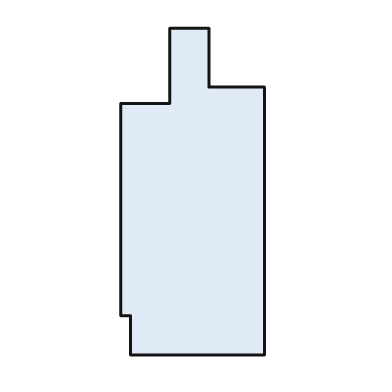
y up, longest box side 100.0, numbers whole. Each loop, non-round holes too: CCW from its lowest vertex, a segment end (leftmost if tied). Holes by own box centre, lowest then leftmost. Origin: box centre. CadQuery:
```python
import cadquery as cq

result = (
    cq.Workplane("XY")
    .moveTo(-19.0, -50.0)
    .lineTo(22.0, -50.0)
    .lineTo(22.0, 32.0)
    .lineTo(5.0, 32.0)
    .lineTo(5.0, 50.0)
    .lineTo(-7.0, 50.0)
    .lineTo(-7.0, 27.0)
    .lineTo(-22.0, 27.0)
    .lineTo(-22.0, -38.0)
    .lineTo(-19.0, -38.0)
    .close()
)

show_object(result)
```